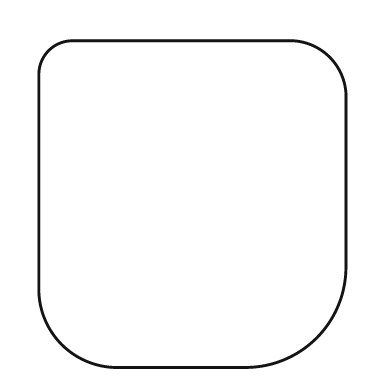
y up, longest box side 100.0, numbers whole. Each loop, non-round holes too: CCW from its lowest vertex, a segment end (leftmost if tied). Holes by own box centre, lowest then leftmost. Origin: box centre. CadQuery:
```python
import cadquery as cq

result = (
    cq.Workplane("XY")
    .moveTo(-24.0, -50.0)
    .lineTo(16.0, -50.0)
    .threePointArc((38.0, -41.0), (47.0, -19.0))
    .lineTo(47.0, 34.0)
    .threePointArc((42.0, 45.0), (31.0, 50.0))
    .lineTo(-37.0, 50.0)
    .threePointArc((-44.0, 47.0), (-47.0, 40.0))
    .lineTo(-47.0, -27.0)
    .threePointArc((-40.0, -43.0), (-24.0, -50.0))
    .close()
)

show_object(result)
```